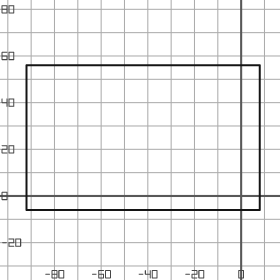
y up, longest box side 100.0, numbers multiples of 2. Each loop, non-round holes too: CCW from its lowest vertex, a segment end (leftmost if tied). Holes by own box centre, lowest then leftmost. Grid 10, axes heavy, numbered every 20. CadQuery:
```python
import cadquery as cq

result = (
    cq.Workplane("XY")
    .moveTo(-92.0, -6.0)
    .lineTo(8.0, -6.0)
    .lineTo(8.0, 56.0)
    .lineTo(-92.0, 56.0)
    .close()
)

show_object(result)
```